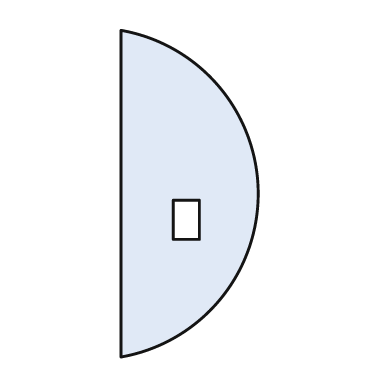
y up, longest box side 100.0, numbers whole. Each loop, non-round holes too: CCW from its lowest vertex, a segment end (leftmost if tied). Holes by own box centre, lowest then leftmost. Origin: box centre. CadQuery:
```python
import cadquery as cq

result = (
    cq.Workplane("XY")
    .moveTo(-21.0, -50.0)
    .threePointArc((21.0, 0.0), (-21.0, 50.0))
    .close()
    .moveTo(-5.0, -14.0)
    .lineTo(3.0, -14.0)
    .lineTo(3.0, -2.0)
    .lineTo(-5.0, -2.0)
    .close()
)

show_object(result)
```